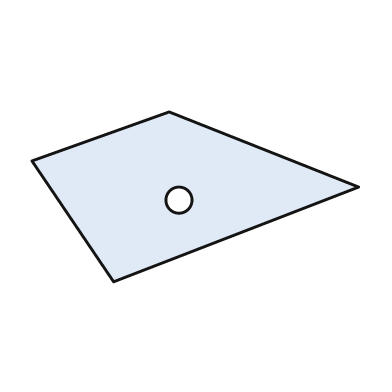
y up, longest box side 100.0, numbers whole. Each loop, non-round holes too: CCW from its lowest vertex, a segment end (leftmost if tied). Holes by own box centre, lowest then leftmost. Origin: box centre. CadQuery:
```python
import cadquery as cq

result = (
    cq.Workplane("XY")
    .moveTo(-25.0, -26.0)
    .lineTo(50.0, 3.0)
    .lineTo(-8.0, 26.0)
    .lineTo(-50.0, 11.0)
    .close()
    .moveTo(-5.0, -1.0)
    .circle(4.0)
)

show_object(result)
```